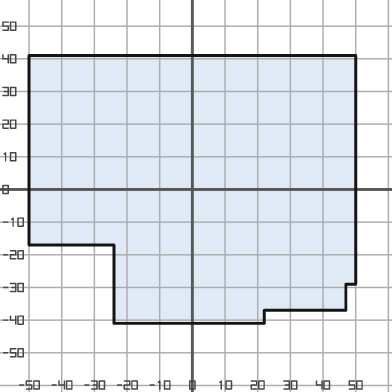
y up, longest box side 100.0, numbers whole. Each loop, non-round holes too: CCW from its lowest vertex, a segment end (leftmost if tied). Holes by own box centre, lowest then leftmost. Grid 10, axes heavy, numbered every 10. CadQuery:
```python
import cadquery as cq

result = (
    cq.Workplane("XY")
    .moveTo(-24.0, -41.0)
    .lineTo(22.0, -41.0)
    .lineTo(22.0, -37.0)
    .lineTo(47.0, -37.0)
    .lineTo(47.0, -29.0)
    .lineTo(50.0, -29.0)
    .lineTo(50.0, 41.0)
    .lineTo(-50.0, 41.0)
    .lineTo(-50.0, -17.0)
    .lineTo(-24.0, -17.0)
    .close()
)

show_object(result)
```